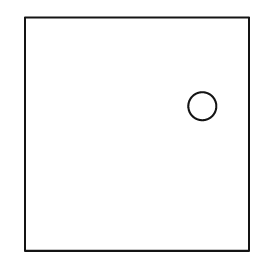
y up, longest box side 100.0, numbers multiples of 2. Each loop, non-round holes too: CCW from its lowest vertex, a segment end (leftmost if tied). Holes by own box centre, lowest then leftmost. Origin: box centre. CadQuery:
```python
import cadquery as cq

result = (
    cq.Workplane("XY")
    .moveTo(-48.0, -50.0)
    .lineTo(48.0, -50.0)
    .lineTo(48.0, 50.0)
    .lineTo(-48.0, 50.0)
    .close()
    .moveTo(28.0, 12.0)
    .circle(6.0)
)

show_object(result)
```